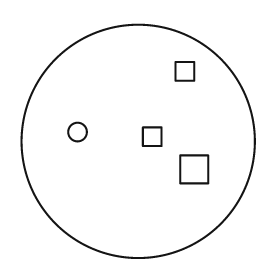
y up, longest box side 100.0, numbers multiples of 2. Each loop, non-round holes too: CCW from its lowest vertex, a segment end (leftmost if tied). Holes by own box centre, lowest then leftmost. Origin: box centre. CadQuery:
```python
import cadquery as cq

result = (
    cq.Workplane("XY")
    .moveTo(0.0, 0.0)
    .circle(50.0)
    .moveTo(18.0, -18.0)
    .lineTo(30.0, -18.0)
    .lineTo(30.0, -6.0)
    .lineTo(18.0, -6.0)
    .close()
    .moveTo(2.0, -2.0)
    .lineTo(10.0, -2.0)
    .lineTo(10.0, 6.0)
    .lineTo(2.0, 6.0)
    .close()
    .moveTo(-26.0, 4.0)
    .circle(4.0)
    .moveTo(16.0, 26.0)
    .lineTo(24.0, 26.0)
    .lineTo(24.0, 34.0)
    .lineTo(16.0, 34.0)
    .close()
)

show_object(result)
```